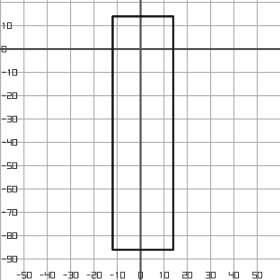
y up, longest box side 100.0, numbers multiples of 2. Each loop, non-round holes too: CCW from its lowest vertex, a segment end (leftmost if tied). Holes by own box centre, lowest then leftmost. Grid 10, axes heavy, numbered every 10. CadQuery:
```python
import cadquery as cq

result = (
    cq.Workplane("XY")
    .moveTo(-12.0, -86.0)
    .lineTo(14.0, -86.0)
    .lineTo(14.0, 14.0)
    .lineTo(-12.0, 14.0)
    .close()
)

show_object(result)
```